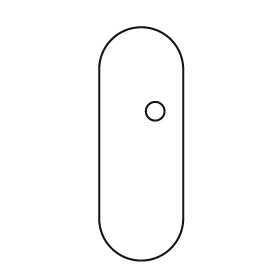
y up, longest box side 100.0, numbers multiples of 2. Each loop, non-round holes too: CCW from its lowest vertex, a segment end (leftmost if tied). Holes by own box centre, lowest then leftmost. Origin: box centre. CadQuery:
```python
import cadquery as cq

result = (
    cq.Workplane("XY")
    .moveTo(-18.0, -32.0)
    .threePointArc((0.0, -50.0), (18.0, -32.0))
    .lineTo(18.0, 32.0)
    .threePointArc((0.0, 50.0), (-18.0, 32.0))
    .close()
    .moveTo(6.0, 14.0)
    .circle(4.0)
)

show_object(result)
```